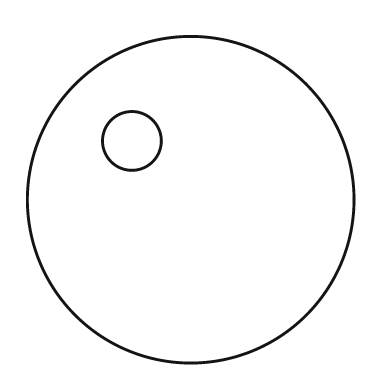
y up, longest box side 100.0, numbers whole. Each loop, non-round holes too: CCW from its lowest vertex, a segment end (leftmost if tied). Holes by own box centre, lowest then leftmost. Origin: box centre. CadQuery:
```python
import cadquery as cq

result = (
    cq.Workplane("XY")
    .moveTo(0.0, 0.0)
    .circle(50.0)
    .moveTo(-18.0, 18.0)
    .circle(9.0)
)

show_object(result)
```